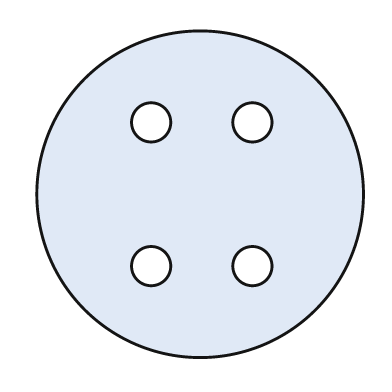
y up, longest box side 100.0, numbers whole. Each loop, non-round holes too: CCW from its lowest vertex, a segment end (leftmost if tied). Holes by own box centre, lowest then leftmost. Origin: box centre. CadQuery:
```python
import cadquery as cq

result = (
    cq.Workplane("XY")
    .moveTo(0.0, 0.0)
    .circle(50.0)
    .moveTo(-15.0, -22.0)
    .circle(6.0)
    .moveTo(16.0, -22.0)
    .circle(6.0)
    .moveTo(-15.0, 22.0)
    .circle(6.0)
    .moveTo(16.0, 22.0)
    .circle(6.0)
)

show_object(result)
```